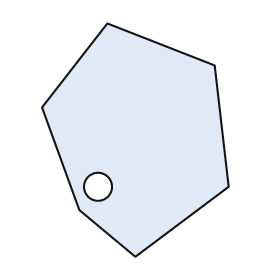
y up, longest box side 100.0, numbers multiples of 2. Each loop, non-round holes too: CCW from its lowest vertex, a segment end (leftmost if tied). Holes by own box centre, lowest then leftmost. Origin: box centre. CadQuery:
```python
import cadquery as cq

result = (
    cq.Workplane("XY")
    .moveTo(0.0, -50.0)
    .lineTo(40.0, -20.0)
    .lineTo(34.0, 32.0)
    .lineTo(-12.0, 50.0)
    .lineTo(-40.0, 14.0)
    .lineTo(-24.0, -30.0)
    .close()
    .moveTo(-16.0, -20.0)
    .circle(6.0)
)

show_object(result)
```